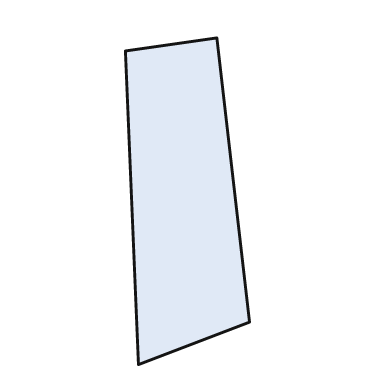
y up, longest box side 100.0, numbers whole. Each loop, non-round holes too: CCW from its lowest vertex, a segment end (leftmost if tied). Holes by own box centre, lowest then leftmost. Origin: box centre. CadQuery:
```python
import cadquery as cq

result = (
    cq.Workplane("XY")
    .moveTo(-15.0, -50.0)
    .lineTo(19.0, -37.0)
    .lineTo(9.0, 50.0)
    .lineTo(-19.0, 46.0)
    .close()
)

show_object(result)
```